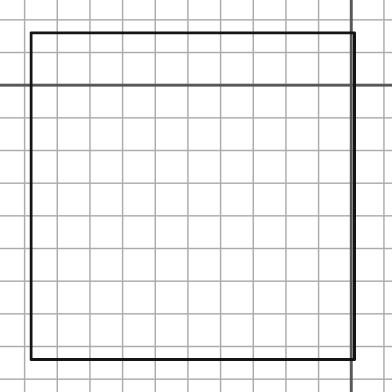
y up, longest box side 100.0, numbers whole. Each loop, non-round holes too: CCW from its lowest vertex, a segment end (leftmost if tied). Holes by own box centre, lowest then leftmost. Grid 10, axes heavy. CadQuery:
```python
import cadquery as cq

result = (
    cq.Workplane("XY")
    .moveTo(-98.0, -84.0)
    .lineTo(1.0, -84.0)
    .lineTo(1.0, 16.0)
    .lineTo(-98.0, 16.0)
    .close()
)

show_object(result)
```